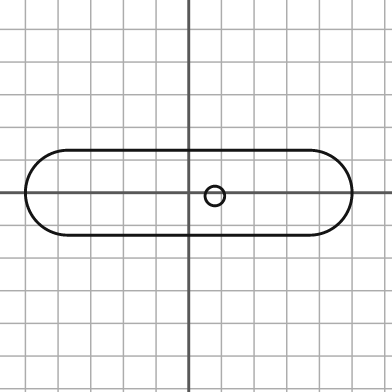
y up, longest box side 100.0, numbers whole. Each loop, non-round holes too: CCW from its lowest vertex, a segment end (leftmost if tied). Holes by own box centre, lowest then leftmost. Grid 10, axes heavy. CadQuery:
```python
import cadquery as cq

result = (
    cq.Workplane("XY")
    .moveTo(-37.0, -13.0)
    .lineTo(37.0, -13.0)
    .threePointArc((50.0, 0.0), (37.0, 13.0))
    .lineTo(-37.0, 13.0)
    .threePointArc((-50.0, 0.0), (-37.0, -13.0))
    .close()
    .moveTo(8.0, -1.0)
    .circle(3.0)
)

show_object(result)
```